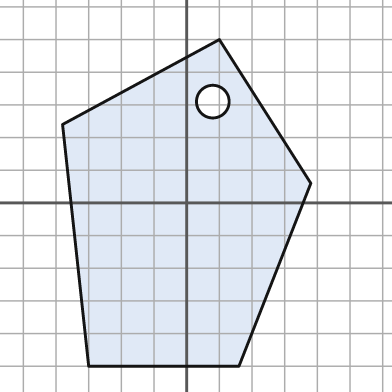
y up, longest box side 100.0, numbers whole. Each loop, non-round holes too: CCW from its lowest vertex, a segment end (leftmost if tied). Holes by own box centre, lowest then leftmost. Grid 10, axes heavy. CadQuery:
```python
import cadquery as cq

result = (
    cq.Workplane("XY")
    .moveTo(-30.0, -50.0)
    .lineTo(16.0, -50.0)
    .lineTo(38.0, 6.0)
    .lineTo(10.0, 50.0)
    .lineTo(-38.0, 24.0)
    .close()
    .moveTo(8.0, 31.0)
    .circle(5.0)
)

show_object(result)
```